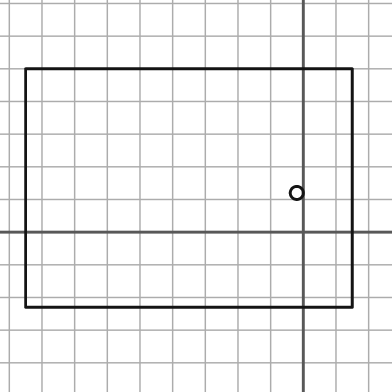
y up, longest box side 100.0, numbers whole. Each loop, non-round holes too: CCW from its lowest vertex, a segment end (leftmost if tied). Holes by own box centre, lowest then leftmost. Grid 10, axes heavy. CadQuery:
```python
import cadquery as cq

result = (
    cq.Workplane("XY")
    .moveTo(-85.0, -23.0)
    .lineTo(15.0, -23.0)
    .lineTo(15.0, 50.0)
    .lineTo(-85.0, 50.0)
    .close()
    .moveTo(-2.0, 12.0)
    .circle(2.0)
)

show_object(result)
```